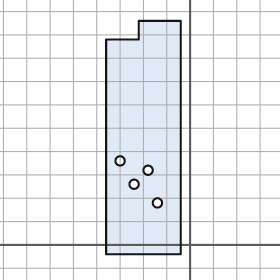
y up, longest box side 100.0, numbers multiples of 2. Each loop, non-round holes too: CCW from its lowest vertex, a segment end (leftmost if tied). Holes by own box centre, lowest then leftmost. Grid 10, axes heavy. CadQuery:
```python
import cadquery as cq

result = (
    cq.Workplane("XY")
    .moveTo(-36.0, -4.0)
    .lineTo(-4.0, -4.0)
    .lineTo(-4.0, 96.0)
    .lineTo(-22.0, 96.0)
    .lineTo(-22.0, 88.0)
    .lineTo(-36.0, 88.0)
    .close()
    .moveTo(-14.0, 18.0)
    .circle(2.0)
    .moveTo(-24.0, 26.0)
    .circle(2.0)
    .moveTo(-18.0, 32.0)
    .circle(2.0)
    .moveTo(-30.0, 36.0)
    .circle(2.0)
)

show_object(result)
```